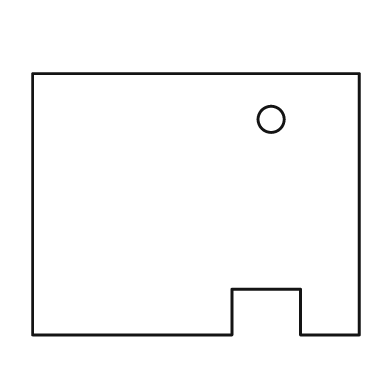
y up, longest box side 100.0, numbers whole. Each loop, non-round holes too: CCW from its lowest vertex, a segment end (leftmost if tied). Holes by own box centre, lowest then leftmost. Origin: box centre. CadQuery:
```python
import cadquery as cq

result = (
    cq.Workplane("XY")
    .moveTo(-50.0, -40.0)
    .lineTo(11.0, -40.0)
    .lineTo(11.0, -26.0)
    .lineTo(32.0, -26.0)
    .lineTo(32.0, -40.0)
    .lineTo(50.0, -40.0)
    .lineTo(50.0, 40.0)
    .lineTo(-50.0, 40.0)
    .close()
    .moveTo(23.0, 26.0)
    .circle(4.0)
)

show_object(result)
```